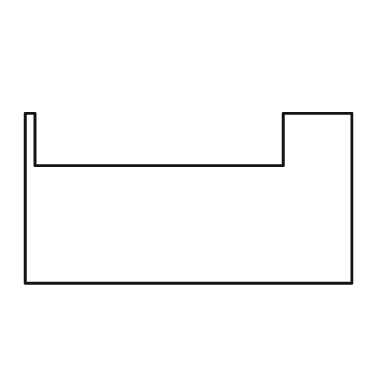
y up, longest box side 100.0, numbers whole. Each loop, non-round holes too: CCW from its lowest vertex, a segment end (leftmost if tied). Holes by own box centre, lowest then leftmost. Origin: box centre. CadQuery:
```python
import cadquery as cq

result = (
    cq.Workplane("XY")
    .moveTo(-50.0, -26.0)
    .lineTo(50.0, -26.0)
    .lineTo(50.0, 26.0)
    .lineTo(29.0, 26.0)
    .lineTo(29.0, 10.0)
    .lineTo(-47.0, 10.0)
    .lineTo(-47.0, 26.0)
    .lineTo(-50.0, 26.0)
    .close()
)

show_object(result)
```